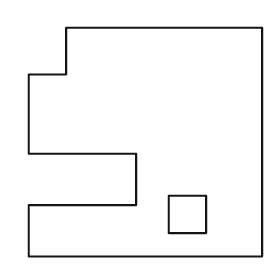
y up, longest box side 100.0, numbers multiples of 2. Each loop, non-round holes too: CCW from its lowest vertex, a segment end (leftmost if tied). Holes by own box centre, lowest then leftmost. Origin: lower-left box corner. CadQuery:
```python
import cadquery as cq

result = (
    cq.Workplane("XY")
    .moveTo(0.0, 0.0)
    .lineTo(100.0, 0.0)
    .lineTo(100.0, 98.0)
    .lineTo(16.0, 98.0)
    .lineTo(16.0, 78.0)
    .lineTo(0.0, 78.0)
    .lineTo(0.0, 44.0)
    .lineTo(46.0, 44.0)
    .lineTo(46.0, 22.0)
    .lineTo(0.0, 22.0)
    .close()
    .moveTo(60.0, 10.0)
    .lineTo(76.0, 10.0)
    .lineTo(76.0, 26.0)
    .lineTo(60.0, 26.0)
    .close()
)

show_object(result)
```